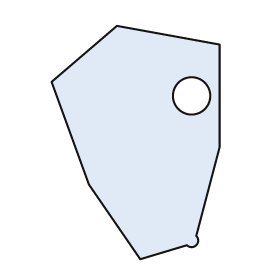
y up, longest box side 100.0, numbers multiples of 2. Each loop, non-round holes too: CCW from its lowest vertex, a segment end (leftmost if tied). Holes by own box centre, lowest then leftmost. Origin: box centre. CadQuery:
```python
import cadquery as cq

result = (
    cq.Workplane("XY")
    .moveTo(2.0, -50.0)
    .lineTo(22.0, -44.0)
    .threePointArc((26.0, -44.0), (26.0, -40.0))
    .lineTo(36.0, -2.0)
    .lineTo(36.0, 42.0)
    .lineTo(-8.0, 50.0)
    .lineTo(-36.0, 26.0)
    .lineTo(-20.0, -18.0)
    .close()
    .moveTo(24.0, 20.0)
    .circle(8.0)
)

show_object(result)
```